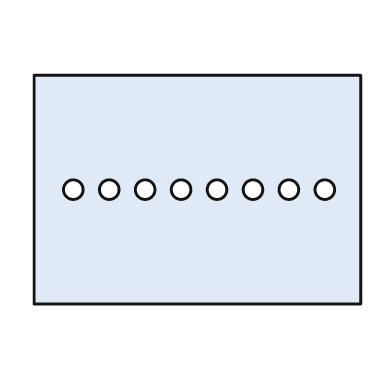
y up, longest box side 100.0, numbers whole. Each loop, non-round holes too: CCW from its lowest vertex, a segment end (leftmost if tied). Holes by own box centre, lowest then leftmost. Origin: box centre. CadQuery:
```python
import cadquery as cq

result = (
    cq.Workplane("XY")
    .moveTo(-50.0, -35.0)
    .lineTo(50.0, -35.0)
    .lineTo(50.0, 35.0)
    .lineTo(-50.0, 35.0)
    .close()
    .moveTo(-38.0, 0.0)
    .circle(3.0)
    .moveTo(-27.0, 0.0)
    .circle(3.0)
    .moveTo(-16.0, 0.0)
    .circle(3.0)
    .moveTo(-5.0, 0.0)
    .circle(3.0)
    .moveTo(6.0, 0.0)
    .circle(3.0)
    .moveTo(17.0, 0.0)
    .circle(3.0)
    .moveTo(28.0, 0.0)
    .circle(3.0)
    .moveTo(39.0, 0.0)
    .circle(3.0)
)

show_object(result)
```